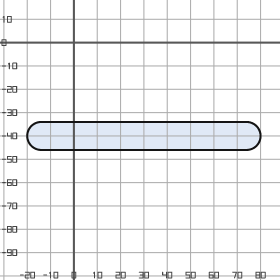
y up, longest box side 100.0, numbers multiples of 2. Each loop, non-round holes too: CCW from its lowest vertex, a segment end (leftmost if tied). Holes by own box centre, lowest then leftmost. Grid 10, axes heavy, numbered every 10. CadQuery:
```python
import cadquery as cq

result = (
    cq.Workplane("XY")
    .moveTo(-14.0, -46.0)
    .lineTo(74.0, -46.0)
    .threePointArc((80.0, -40.0), (74.0, -34.0))
    .lineTo(-14.0, -34.0)
    .threePointArc((-20.0, -40.0), (-14.0, -46.0))
    .close()
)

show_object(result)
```